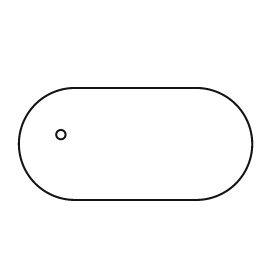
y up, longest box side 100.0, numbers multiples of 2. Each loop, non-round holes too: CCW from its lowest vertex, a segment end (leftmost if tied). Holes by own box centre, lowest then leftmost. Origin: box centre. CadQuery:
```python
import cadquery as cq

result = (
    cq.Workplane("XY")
    .moveTo(-26.0, -24.0)
    .lineTo(26.0, -24.0)
    .threePointArc((50.0, 0.0), (26.0, 24.0))
    .lineTo(-26.0, 24.0)
    .threePointArc((-50.0, 0.0), (-26.0, -24.0))
    .close()
    .moveTo(-32.0, 4.0)
    .circle(2.0)
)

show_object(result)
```